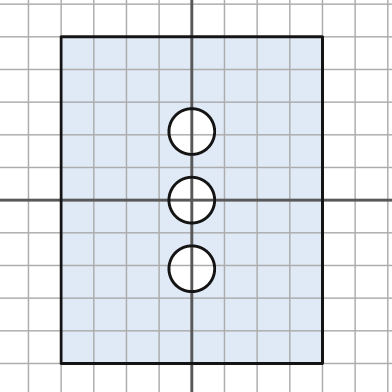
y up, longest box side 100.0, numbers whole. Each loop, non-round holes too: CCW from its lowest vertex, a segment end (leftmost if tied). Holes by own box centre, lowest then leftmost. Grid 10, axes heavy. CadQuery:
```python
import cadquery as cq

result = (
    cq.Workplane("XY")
    .moveTo(-40.0, -50.0)
    .lineTo(40.0, -50.0)
    .lineTo(40.0, 50.0)
    .lineTo(-40.0, 50.0)
    .close()
    .moveTo(0.0, -21.0)
    .circle(7.0)
    .moveTo(0.0, 0.0)
    .circle(7.0)
    .moveTo(0.0, 21.0)
    .circle(7.0)
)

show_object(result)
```